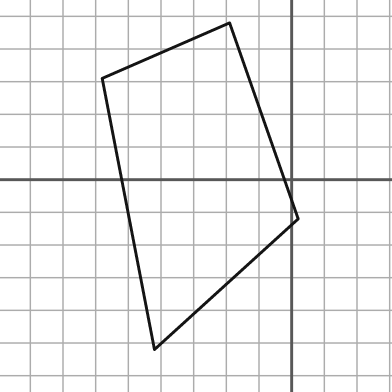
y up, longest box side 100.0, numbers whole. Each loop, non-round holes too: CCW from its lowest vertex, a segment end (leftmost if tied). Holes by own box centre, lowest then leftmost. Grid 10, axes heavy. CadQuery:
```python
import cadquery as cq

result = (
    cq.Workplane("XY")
    .moveTo(-42.0, -52.0)
    .lineTo(2.0, -12.0)
    .lineTo(-19.0, 48.0)
    .lineTo(-58.0, 31.0)
    .close()
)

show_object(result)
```